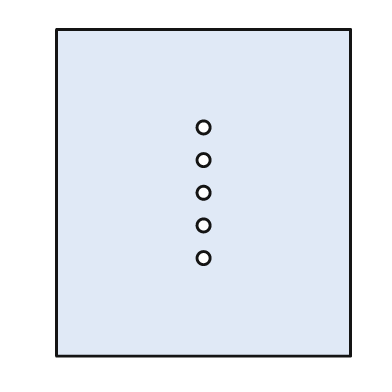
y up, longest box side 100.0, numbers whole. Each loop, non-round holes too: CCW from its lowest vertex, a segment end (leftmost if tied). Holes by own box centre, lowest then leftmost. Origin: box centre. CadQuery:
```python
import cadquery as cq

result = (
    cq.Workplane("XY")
    .moveTo(-45.0, -50.0)
    .lineTo(45.0, -50.0)
    .lineTo(45.0, 50.0)
    .lineTo(-45.0, 50.0)
    .close()
    .moveTo(0.0, -20.0)
    .circle(2.0)
    .moveTo(0.0, -10.0)
    .circle(2.0)
    .moveTo(0.0, 0.0)
    .circle(2.0)
    .moveTo(0.0, 10.0)
    .circle(2.0)
    .moveTo(0.0, 20.0)
    .circle(2.0)
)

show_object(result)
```